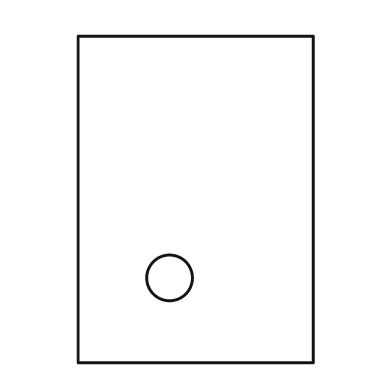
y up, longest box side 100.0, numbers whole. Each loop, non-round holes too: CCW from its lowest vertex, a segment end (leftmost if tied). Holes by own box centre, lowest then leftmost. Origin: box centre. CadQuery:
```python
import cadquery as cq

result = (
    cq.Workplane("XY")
    .moveTo(-36.0, -50.0)
    .lineTo(36.0, -50.0)
    .lineTo(36.0, 50.0)
    .lineTo(-36.0, 50.0)
    .close()
    .moveTo(-8.0, -24.0)
    .circle(7.0)
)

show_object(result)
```